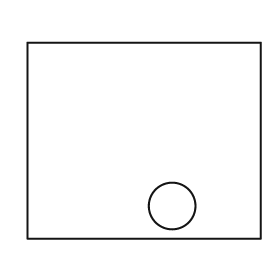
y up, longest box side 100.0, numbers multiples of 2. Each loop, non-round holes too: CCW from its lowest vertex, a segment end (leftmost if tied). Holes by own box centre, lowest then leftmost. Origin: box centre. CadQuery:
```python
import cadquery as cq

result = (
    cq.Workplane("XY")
    .moveTo(-50.0, -42.0)
    .lineTo(50.0, -42.0)
    .lineTo(50.0, 42.0)
    .lineTo(-50.0, 42.0)
    .close()
    .moveTo(12.0, -28.0)
    .circle(10.0)
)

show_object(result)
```